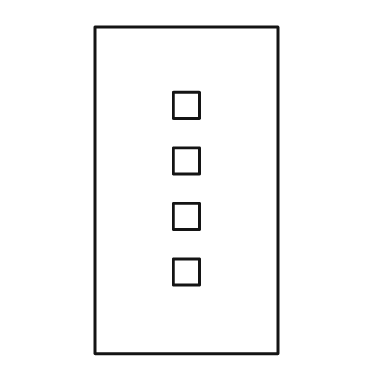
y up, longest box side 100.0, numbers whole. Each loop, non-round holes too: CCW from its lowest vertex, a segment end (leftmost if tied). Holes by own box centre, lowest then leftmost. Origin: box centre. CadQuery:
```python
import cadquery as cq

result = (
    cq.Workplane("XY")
    .moveTo(-28.0, -50.0)
    .lineTo(28.0, -50.0)
    .lineTo(28.0, 50.0)
    .lineTo(-28.0, 50.0)
    .close()
    .moveTo(-4.0, -29.0)
    .lineTo(4.0, -29.0)
    .lineTo(4.0, -21.0)
    .lineTo(-4.0, -21.0)
    .close()
    .moveTo(-4.0, -12.0)
    .lineTo(4.0, -12.0)
    .lineTo(4.0, -4.0)
    .lineTo(-4.0, -4.0)
    .close()
    .moveTo(-4.0, 5.0)
    .lineTo(4.0, 5.0)
    .lineTo(4.0, 13.0)
    .lineTo(-4.0, 13.0)
    .close()
    .moveTo(-4.0, 22.0)
    .lineTo(4.0, 22.0)
    .lineTo(4.0, 30.0)
    .lineTo(-4.0, 30.0)
    .close()
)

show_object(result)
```